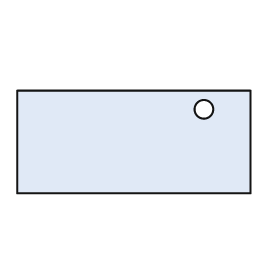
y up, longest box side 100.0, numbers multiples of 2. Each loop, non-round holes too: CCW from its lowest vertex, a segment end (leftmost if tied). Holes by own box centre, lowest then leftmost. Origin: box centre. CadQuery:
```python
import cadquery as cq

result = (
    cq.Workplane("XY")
    .moveTo(-50.0, -22.0)
    .lineTo(50.0, -22.0)
    .lineTo(50.0, 22.0)
    .lineTo(-50.0, 22.0)
    .close()
    .moveTo(30.0, 14.0)
    .circle(4.0)
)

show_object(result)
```